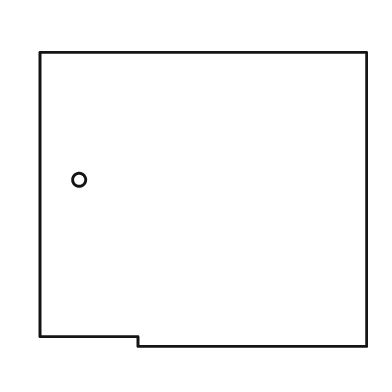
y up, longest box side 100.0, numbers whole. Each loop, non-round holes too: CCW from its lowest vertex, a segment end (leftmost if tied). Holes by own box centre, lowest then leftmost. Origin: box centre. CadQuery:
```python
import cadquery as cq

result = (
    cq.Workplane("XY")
    .moveTo(-20.0, -45.0)
    .lineTo(50.0, -45.0)
    .lineTo(50.0, 45.0)
    .lineTo(-50.0, 45.0)
    .lineTo(-50.0, -42.0)
    .lineTo(-20.0, -42.0)
    .close()
    .moveTo(-38.0, 6.0)
    .circle(2.0)
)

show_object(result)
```